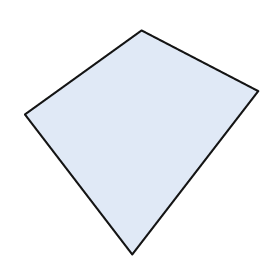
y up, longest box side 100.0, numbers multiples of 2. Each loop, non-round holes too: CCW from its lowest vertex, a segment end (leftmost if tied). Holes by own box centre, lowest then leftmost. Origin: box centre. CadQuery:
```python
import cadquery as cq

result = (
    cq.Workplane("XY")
    .moveTo(-4.0, -48.0)
    .lineTo(50.0, 22.0)
    .lineTo(0.0, 48.0)
    .lineTo(-50.0, 12.0)
    .close()
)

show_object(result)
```